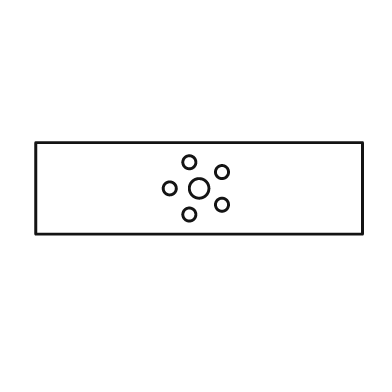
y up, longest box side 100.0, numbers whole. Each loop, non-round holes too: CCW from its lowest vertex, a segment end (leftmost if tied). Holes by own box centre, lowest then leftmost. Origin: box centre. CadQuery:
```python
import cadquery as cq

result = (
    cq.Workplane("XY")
    .moveTo(-50.0, -14.0)
    .lineTo(50.0, -14.0)
    .lineTo(50.0, 14.0)
    .lineTo(-50.0, 14.0)
    .close()
    .moveTo(-3.0, -8.0)
    .circle(2.0)
    .moveTo(7.0, -5.0)
    .circle(2.0)
    .moveTo(-9.0, 0.0)
    .circle(2.0)
    .moveTo(0.0, 0.0)
    .circle(3.0)
    .moveTo(7.0, 5.0)
    .circle(2.0)
    .moveTo(-3.0, 8.0)
    .circle(2.0)
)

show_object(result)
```